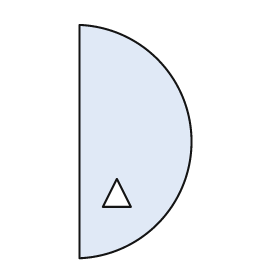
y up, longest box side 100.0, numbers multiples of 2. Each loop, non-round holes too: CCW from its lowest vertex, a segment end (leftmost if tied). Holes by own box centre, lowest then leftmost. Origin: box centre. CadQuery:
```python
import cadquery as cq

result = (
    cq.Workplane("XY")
    .moveTo(-24.0, -50.0)
    .threePointArc((24.0, 0.0), (-24.0, 50.0))
    .close()
    .moveTo(-14.0, -28.0)
    .lineTo(-2.0, -28.0)
    .lineTo(-8.0, -16.0)
    .close()
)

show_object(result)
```